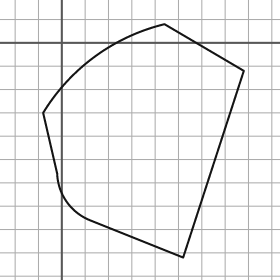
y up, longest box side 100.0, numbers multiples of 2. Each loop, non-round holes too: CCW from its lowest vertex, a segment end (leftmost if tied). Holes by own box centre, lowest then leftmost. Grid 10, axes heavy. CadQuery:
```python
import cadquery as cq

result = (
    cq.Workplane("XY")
    .moveTo(52.0, -92.0)
    .lineTo(78.0, -12.0)
    .lineTo(44.0, 8.0)
    .threePointArc((14.0, -6.0), (-8.0, -30.0))
    .lineTo(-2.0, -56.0)
    .threePointArc((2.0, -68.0), (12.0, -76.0))
    .close()
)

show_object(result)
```